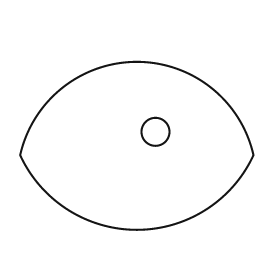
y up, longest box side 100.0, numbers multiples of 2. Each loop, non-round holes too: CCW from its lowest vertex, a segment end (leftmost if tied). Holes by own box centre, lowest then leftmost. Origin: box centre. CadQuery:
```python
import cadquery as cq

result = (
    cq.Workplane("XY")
    .moveTo(-50.0, -4.0)
    .threePointArc((0.0, -36.0), (50.0, -4.0))
    .threePointArc((0.0, 36.0), (-50.0, -4.0))
    .close()
    .moveTo(8.0, 6.0)
    .circle(6.0)
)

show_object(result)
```